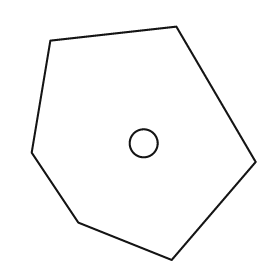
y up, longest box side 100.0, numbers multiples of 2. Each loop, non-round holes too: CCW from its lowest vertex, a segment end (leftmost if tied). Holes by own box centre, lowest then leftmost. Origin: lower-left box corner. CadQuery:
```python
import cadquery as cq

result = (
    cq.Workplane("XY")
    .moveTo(60.0, 0.0)
    .lineTo(96.0, 42.0)
    .lineTo(62.0, 100.0)
    .lineTo(8.0, 94.0)
    .lineTo(0.0, 46.0)
    .lineTo(20.0, 16.0)
    .close()
    .moveTo(48.0, 50.0)
    .circle(6.0)
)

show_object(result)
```